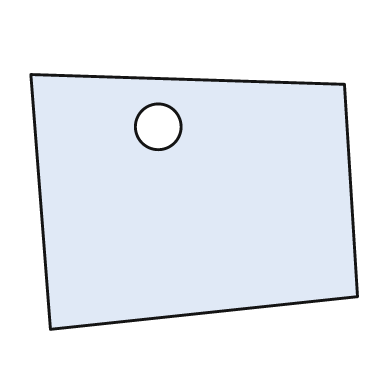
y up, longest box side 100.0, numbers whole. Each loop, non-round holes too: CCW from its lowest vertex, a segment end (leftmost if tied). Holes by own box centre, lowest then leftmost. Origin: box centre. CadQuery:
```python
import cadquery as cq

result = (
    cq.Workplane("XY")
    .moveTo(-44.0, -39.0)
    .lineTo(50.0, -29.0)
    .lineTo(46.0, 36.0)
    .lineTo(-50.0, 39.0)
    .close()
    .moveTo(-11.0, 23.0)
    .circle(7.0)
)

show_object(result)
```